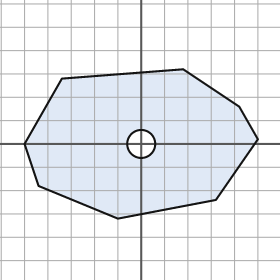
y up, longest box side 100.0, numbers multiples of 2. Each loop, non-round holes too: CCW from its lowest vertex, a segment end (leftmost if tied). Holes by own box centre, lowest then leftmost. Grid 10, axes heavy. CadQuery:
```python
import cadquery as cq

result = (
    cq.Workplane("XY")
    .moveTo(-10.0, -32.0)
    .lineTo(32.0, -24.0)
    .lineTo(50.0, 2.0)
    .lineTo(42.0, 16.0)
    .lineTo(18.0, 32.0)
    .lineTo(-34.0, 28.0)
    .lineTo(-50.0, 0.0)
    .lineTo(-44.0, -18.0)
    .close()
    .moveTo(0.0, 0.0)
    .circle(6.0)
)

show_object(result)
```